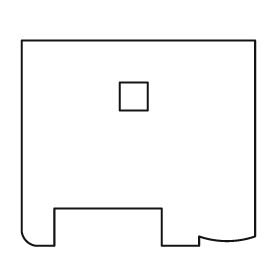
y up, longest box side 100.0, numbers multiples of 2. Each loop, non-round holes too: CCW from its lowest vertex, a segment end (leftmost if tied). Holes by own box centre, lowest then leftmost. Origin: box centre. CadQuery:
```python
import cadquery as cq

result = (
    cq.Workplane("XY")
    .moveTo(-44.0, -44.0)
    .lineTo(-36.0, -44.0)
    .lineTo(-36.0, -28.0)
    .lineTo(10.0, -28.0)
    .lineTo(10.0, -44.0)
    .lineTo(26.0, -44.0)
    .lineTo(26.0, -40.0)
    .threePointArc((38.0, -42.0), (50.0, -40.0))
    .lineTo(50.0, 44.0)
    .lineTo(-50.0, 44.0)
    .lineTo(-50.0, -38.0)
    .threePointArc((-48.0, -42.0), (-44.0, -44.0))
    .close()
    .moveTo(-8.0, 14.0)
    .lineTo(4.0, 14.0)
    .lineTo(4.0, 26.0)
    .lineTo(-8.0, 26.0)
    .close()
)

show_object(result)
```